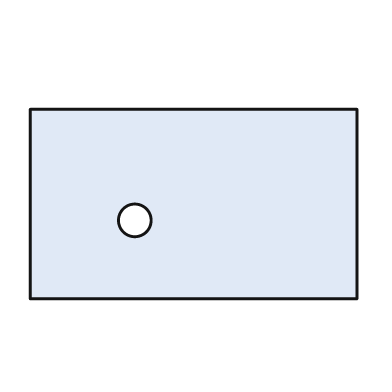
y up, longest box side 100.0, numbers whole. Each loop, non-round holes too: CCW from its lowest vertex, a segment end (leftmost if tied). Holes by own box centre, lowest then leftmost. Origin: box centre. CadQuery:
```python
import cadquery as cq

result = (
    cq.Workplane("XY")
    .moveTo(-50.0, -29.0)
    .lineTo(50.0, -29.0)
    .lineTo(50.0, 29.0)
    .lineTo(-50.0, 29.0)
    .close()
    .moveTo(-18.0, -5.0)
    .circle(5.0)
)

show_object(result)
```